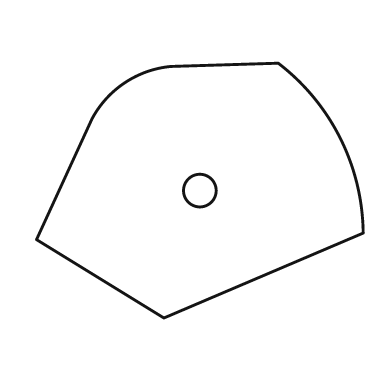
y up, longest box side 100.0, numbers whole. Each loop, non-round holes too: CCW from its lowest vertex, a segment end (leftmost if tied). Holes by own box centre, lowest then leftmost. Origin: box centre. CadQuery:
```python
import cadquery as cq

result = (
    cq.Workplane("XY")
    .moveTo(-11.0, -39.0)
    .lineTo(50.0, -13.0)
    .threePointArc((43.0, 16.0), (24.0, 39.0))
    .lineTo(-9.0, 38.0)
    .threePointArc((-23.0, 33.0), (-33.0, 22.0))
    .lineTo(-50.0, -15.0)
    .close()
    .moveTo(0.0, 0.0)
    .circle(5.0)
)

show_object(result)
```